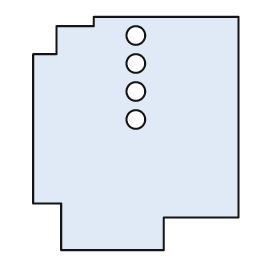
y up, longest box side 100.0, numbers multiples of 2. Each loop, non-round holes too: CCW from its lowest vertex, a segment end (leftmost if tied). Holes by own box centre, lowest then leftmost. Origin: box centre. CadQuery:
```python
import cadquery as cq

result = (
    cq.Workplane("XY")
    .moveTo(-32.0, -50.0)
    .lineTo(12.0, -50.0)
    .lineTo(12.0, -36.0)
    .lineTo(44.0, -36.0)
    .lineTo(44.0, 50.0)
    .lineTo(-18.0, 50.0)
    .lineTo(-18.0, 46.0)
    .lineTo(-34.0, 46.0)
    .lineTo(-34.0, 34.0)
    .lineTo(-44.0, 34.0)
    .lineTo(-44.0, -30.0)
    .lineTo(-32.0, -30.0)
    .close()
    .moveTo(0.0, 6.0)
    .circle(4.0)
    .moveTo(0.0, 18.0)
    .circle(4.0)
    .moveTo(0.0, 30.0)
    .circle(4.0)
    .moveTo(0.0, 42.0)
    .circle(4.0)
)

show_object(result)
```